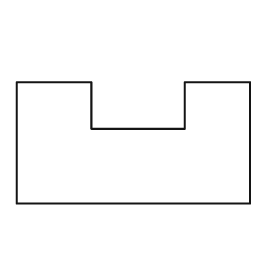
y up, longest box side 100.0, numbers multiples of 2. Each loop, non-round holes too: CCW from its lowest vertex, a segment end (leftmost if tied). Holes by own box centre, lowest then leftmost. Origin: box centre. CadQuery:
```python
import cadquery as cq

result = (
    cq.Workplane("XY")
    .moveTo(-50.0, -26.0)
    .lineTo(50.0, -26.0)
    .lineTo(50.0, 26.0)
    .lineTo(22.0, 26.0)
    .lineTo(22.0, 6.0)
    .lineTo(-18.0, 6.0)
    .lineTo(-18.0, 26.0)
    .lineTo(-50.0, 26.0)
    .close()
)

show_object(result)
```